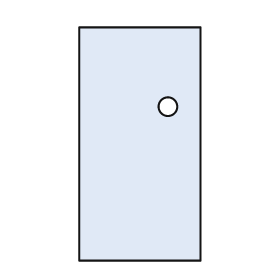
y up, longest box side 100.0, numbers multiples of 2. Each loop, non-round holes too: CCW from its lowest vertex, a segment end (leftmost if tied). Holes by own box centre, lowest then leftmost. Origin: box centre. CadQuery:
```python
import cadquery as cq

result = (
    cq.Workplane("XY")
    .moveTo(-26.0, -50.0)
    .lineTo(26.0, -50.0)
    .lineTo(26.0, 50.0)
    .lineTo(-26.0, 50.0)
    .close()
    .moveTo(12.0, 16.0)
    .circle(4.0)
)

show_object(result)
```